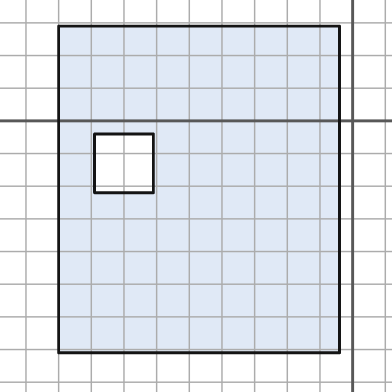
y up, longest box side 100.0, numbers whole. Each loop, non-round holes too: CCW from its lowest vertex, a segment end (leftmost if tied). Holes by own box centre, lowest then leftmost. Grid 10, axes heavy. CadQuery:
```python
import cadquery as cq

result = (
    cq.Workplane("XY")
    .moveTo(-90.0, -71.0)
    .lineTo(-4.0, -71.0)
    .lineTo(-4.0, 29.0)
    .lineTo(-90.0, 29.0)
    .close()
    .moveTo(-79.0, -22.0)
    .lineTo(-61.0, -22.0)
    .lineTo(-61.0, -4.0)
    .lineTo(-79.0, -4.0)
    .close()
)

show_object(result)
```